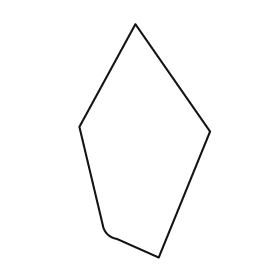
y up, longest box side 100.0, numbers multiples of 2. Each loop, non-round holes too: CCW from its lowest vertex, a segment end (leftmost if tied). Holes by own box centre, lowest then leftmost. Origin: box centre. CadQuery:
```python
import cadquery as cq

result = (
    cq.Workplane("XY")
    .moveTo(6.0, -50.0)
    .lineTo(28.0, 4.0)
    .lineTo(-4.0, 50.0)
    .lineTo(-28.0, 6.0)
    .lineTo(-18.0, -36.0)
    .threePointArc((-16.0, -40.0), (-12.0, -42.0))
    .close()
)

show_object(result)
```